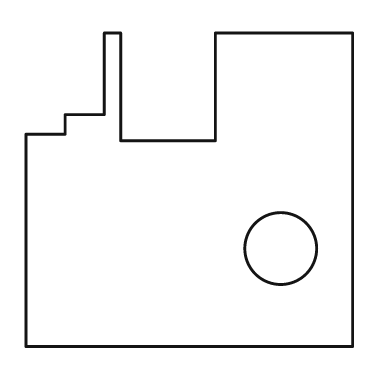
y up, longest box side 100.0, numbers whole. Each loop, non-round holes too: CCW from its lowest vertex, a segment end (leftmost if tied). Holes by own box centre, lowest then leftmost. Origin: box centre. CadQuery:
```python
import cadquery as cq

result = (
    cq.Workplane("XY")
    .moveTo(-50.0, -48.0)
    .lineTo(50.0, -48.0)
    .lineTo(50.0, 48.0)
    .lineTo(8.0, 48.0)
    .lineTo(8.0, 15.0)
    .lineTo(-21.0, 15.0)
    .lineTo(-21.0, 48.0)
    .lineTo(-26.0, 48.0)
    .lineTo(-26.0, 23.0)
    .lineTo(-38.0, 23.0)
    .lineTo(-38.0, 17.0)
    .lineTo(-50.0, 17.0)
    .close()
    .moveTo(28.0, -18.0)
    .circle(11.0)
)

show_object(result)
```